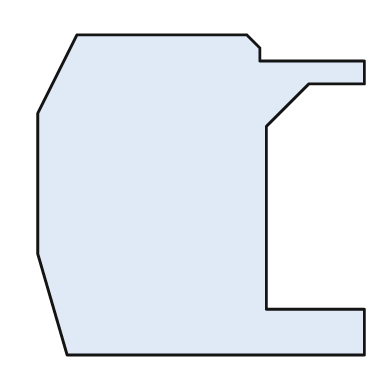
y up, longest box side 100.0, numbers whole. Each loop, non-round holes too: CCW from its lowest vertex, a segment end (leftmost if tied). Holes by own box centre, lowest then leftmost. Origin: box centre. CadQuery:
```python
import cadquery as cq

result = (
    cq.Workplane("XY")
    .moveTo(-41.0, -49.0)
    .lineTo(50.0, -49.0)
    .lineTo(50.0, -35.0)
    .lineTo(20.0, -35.0)
    .lineTo(20.0, 21.0)
    .lineTo(33.0, 34.0)
    .lineTo(50.0, 34.0)
    .lineTo(50.0, 41.0)
    .lineTo(18.0, 41.0)
    .lineTo(18.0, 45.0)
    .lineTo(14.0, 49.0)
    .lineTo(-38.0, 49.0)
    .lineTo(-50.0, 25.0)
    .lineTo(-50.0, -18.0)
    .close()
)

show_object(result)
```